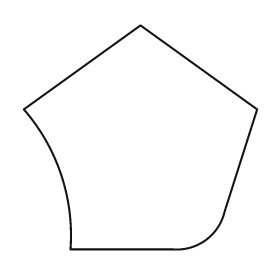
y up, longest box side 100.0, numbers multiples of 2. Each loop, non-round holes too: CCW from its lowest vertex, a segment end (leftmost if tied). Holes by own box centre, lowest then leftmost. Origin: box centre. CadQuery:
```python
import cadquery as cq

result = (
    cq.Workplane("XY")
    .moveTo(-30.0, -48.0)
    .lineTo(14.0, -48.0)
    .threePointArc((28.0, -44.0), (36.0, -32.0))
    .lineTo(50.0, 12.0)
    .lineTo(0.0, 48.0)
    .lineTo(-50.0, 12.0)
    .threePointArc((-34.0, -16.0), (-30.0, -48.0))
    .close()
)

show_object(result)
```